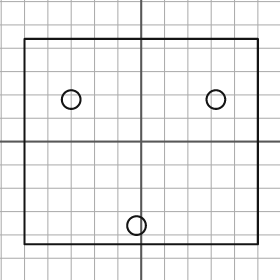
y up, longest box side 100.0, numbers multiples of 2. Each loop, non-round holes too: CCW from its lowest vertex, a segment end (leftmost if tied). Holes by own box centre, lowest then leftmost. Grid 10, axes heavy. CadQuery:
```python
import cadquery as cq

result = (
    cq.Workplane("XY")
    .moveTo(-50.0, -44.0)
    .lineTo(50.0, -44.0)
    .lineTo(50.0, 44.0)
    .lineTo(-50.0, 44.0)
    .close()
    .moveTo(-2.0, -36.0)
    .circle(4.0)
    .moveTo(-30.0, 18.0)
    .circle(4.0)
    .moveTo(32.0, 18.0)
    .circle(4.0)
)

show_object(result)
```